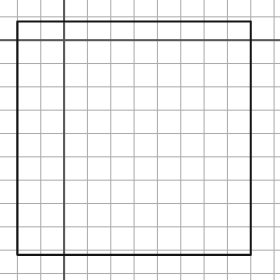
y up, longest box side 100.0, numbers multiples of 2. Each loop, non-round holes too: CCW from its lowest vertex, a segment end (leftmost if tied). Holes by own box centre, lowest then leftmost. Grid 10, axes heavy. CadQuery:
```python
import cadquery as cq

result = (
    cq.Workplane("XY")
    .moveTo(-20.0, -92.0)
    .lineTo(80.0, -92.0)
    .lineTo(80.0, 8.0)
    .lineTo(-20.0, 8.0)
    .close()
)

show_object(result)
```